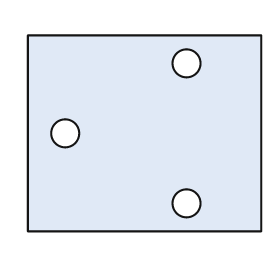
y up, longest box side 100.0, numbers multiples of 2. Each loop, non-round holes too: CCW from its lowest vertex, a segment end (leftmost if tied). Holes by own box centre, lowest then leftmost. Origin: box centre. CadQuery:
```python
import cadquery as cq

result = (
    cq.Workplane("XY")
    .moveTo(-50.0, -42.0)
    .lineTo(50.0, -42.0)
    .lineTo(50.0, 42.0)
    .lineTo(-50.0, 42.0)
    .close()
    .moveTo(18.0, -30.0)
    .circle(6.0)
    .moveTo(-34.0, 0.0)
    .circle(6.0)
    .moveTo(18.0, 30.0)
    .circle(6.0)
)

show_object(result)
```